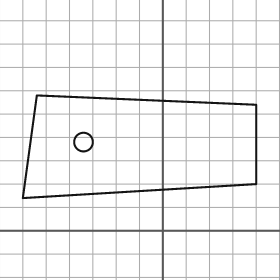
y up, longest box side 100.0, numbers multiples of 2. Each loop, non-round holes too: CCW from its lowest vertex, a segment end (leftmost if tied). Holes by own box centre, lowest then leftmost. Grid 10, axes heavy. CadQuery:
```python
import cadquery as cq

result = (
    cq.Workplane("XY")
    .moveTo(-60.0, 14.0)
    .lineTo(40.0, 20.0)
    .lineTo(40.0, 54.0)
    .lineTo(-54.0, 58.0)
    .close()
    .moveTo(-34.0, 38.0)
    .circle(4.0)
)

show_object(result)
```